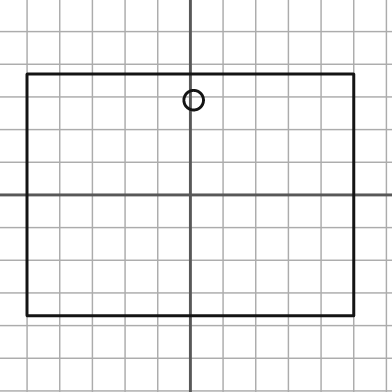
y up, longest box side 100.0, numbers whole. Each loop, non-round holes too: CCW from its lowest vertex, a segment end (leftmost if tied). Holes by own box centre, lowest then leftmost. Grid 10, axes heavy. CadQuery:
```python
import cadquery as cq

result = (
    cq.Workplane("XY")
    .moveTo(-50.0, -37.0)
    .lineTo(50.0, -37.0)
    .lineTo(50.0, 37.0)
    .lineTo(-50.0, 37.0)
    .close()
    .moveTo(1.0, 29.0)
    .circle(3.0)
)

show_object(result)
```